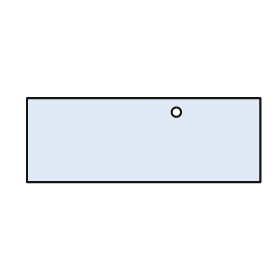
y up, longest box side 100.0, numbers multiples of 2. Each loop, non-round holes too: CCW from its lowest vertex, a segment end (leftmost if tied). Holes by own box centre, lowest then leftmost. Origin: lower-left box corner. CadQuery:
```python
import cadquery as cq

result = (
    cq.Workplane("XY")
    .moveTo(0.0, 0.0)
    .lineTo(100.0, 0.0)
    .lineTo(100.0, 36.0)
    .lineTo(0.0, 36.0)
    .close()
    .moveTo(64.0, 30.0)
    .circle(2.0)
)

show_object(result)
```